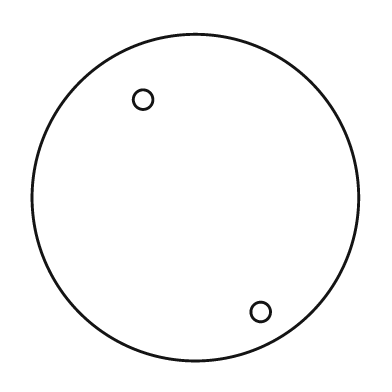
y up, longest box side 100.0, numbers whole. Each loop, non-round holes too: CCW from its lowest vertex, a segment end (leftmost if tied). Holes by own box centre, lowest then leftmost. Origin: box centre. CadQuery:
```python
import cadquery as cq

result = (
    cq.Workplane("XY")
    .moveTo(0.0, 0.0)
    .circle(50.0)
    .moveTo(20.0, -35.0)
    .circle(3.0)
    .moveTo(-16.0, 30.0)
    .circle(3.0)
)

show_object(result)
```